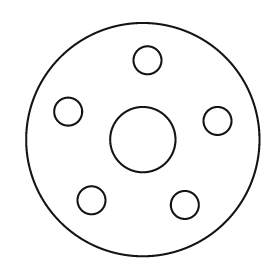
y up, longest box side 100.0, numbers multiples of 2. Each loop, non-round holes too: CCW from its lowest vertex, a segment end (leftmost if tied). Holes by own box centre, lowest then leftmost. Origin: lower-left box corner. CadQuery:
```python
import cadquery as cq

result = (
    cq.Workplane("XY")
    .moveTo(50.0, 50.0)
    .circle(50.0)
    .moveTo(68.0, 22.0)
    .circle(6.0)
    .moveTo(28.0, 24.0)
    .circle(6.0)
    .moveTo(50.0, 50.0)
    .circle(14.0)
    .moveTo(82.0, 58.0)
    .circle(6.0)
    .moveTo(18.0, 62.0)
    .circle(6.0)
    .moveTo(52.0, 84.0)
    .circle(6.0)
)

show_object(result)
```